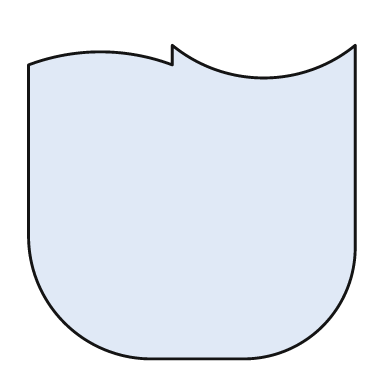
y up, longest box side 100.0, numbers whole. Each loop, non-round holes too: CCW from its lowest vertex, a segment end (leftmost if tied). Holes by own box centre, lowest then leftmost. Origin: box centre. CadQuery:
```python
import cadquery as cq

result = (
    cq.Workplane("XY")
    .moveTo(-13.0, -48.0)
    .lineTo(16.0, -48.0)
    .threePointArc((40.0, -38.0), (50.0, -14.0))
    .lineTo(50.0, 48.0)
    .threePointArc((22.0, 38.0), (-6.0, 48.0))
    .lineTo(-6.0, 42.0)
    .threePointArc((-28.0, 46.0), (-50.0, 42.0))
    .lineTo(-50.0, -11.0)
    .threePointArc((-39.0, -37.0), (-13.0, -48.0))
    .close()
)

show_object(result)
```